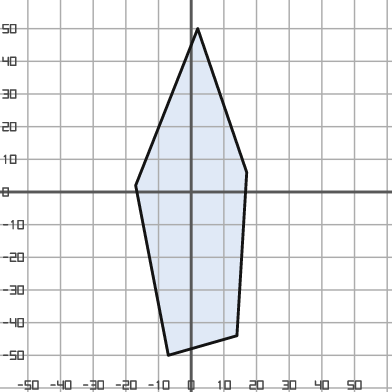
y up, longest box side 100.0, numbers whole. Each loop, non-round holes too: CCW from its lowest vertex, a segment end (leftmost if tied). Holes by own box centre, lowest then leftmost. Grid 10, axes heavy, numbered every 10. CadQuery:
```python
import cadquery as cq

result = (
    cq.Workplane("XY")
    .moveTo(-7.0, -50.0)
    .lineTo(14.0, -44.0)
    .lineTo(17.0, 6.0)
    .lineTo(2.0, 50.0)
    .lineTo(-17.0, 2.0)
    .close()
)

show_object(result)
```